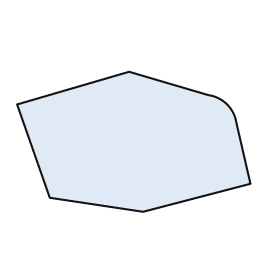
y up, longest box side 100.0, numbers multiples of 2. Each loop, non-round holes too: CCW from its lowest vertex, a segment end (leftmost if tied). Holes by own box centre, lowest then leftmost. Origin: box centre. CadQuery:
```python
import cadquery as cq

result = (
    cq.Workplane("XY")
    .moveTo(4.0, -30.0)
    .lineTo(50.0, -18.0)
    .lineTo(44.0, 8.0)
    .threePointArc((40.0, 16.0), (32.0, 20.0))
    .lineTo(-2.0, 30.0)
    .lineTo(-50.0, 16.0)
    .lineTo(-36.0, -24.0)
    .close()
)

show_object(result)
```